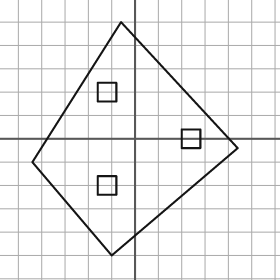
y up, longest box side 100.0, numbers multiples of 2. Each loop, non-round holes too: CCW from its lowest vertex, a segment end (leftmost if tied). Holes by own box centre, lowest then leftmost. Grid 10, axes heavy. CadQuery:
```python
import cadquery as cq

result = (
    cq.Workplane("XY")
    .moveTo(-10.0, -50.0)
    .lineTo(44.0, -4.0)
    .lineTo(-6.0, 50.0)
    .lineTo(-44.0, -10.0)
    .close()
    .moveTo(-16.0, -24.0)
    .lineTo(-8.0, -24.0)
    .lineTo(-8.0, -16.0)
    .lineTo(-16.0, -16.0)
    .close()
    .moveTo(20.0, -4.0)
    .lineTo(28.0, -4.0)
    .lineTo(28.0, 4.0)
    .lineTo(20.0, 4.0)
    .close()
    .moveTo(-16.0, 16.0)
    .lineTo(-8.0, 16.0)
    .lineTo(-8.0, 24.0)
    .lineTo(-16.0, 24.0)
    .close()
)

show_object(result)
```